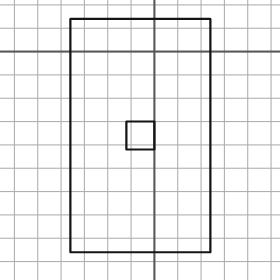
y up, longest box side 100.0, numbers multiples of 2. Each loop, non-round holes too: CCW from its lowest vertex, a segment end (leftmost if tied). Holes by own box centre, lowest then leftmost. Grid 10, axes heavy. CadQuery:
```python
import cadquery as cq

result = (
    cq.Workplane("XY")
    .moveTo(-36.0, -86.0)
    .lineTo(24.0, -86.0)
    .lineTo(24.0, 14.0)
    .lineTo(-36.0, 14.0)
    .close()
    .moveTo(-12.0, -42.0)
    .lineTo(0.0, -42.0)
    .lineTo(0.0, -30.0)
    .lineTo(-12.0, -30.0)
    .close()
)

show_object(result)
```